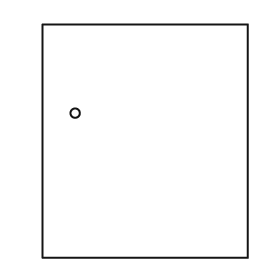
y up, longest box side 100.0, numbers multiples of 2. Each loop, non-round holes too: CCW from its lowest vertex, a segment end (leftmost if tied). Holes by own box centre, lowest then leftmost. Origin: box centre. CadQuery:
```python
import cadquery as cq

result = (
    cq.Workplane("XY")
    .moveTo(-44.0, -50.0)
    .lineTo(44.0, -50.0)
    .lineTo(44.0, 50.0)
    .lineTo(-44.0, 50.0)
    .close()
    .moveTo(-30.0, 12.0)
    .circle(2.0)
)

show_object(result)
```